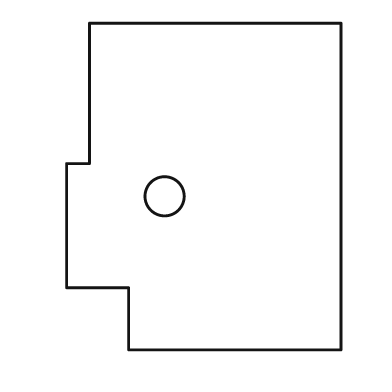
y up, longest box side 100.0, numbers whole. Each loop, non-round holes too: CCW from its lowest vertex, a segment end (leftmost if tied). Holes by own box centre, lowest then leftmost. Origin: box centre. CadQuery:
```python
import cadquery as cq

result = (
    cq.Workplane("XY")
    .moveTo(-23.0, -50.0)
    .lineTo(42.0, -50.0)
    .lineTo(42.0, 50.0)
    .lineTo(-35.0, 50.0)
    .lineTo(-35.0, 7.0)
    .lineTo(-42.0, 7.0)
    .lineTo(-42.0, -31.0)
    .lineTo(-23.0, -31.0)
    .close()
    .moveTo(-12.0, -3.0)
    .circle(6.0)
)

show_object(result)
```